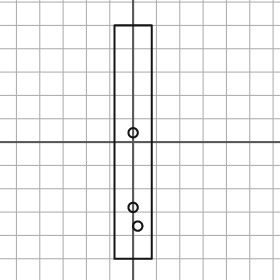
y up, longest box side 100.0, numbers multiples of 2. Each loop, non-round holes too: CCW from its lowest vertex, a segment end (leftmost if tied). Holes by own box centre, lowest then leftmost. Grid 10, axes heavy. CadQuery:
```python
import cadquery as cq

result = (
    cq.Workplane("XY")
    .moveTo(-8.0, -50.0)
    .lineTo(8.0, -50.0)
    .lineTo(8.0, 50.0)
    .lineTo(-8.0, 50.0)
    .close()
    .moveTo(2.0, -36.0)
    .circle(2.0)
    .moveTo(0.0, -28.0)
    .circle(2.0)
    .moveTo(0.0, 4.0)
    .circle(2.0)
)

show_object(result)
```